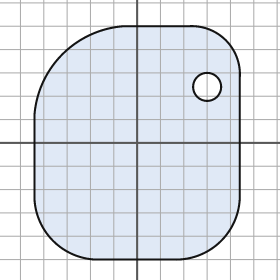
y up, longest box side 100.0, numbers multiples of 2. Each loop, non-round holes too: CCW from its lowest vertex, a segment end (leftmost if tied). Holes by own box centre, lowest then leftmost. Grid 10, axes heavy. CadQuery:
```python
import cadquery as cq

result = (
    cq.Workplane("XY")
    .moveTo(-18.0, -50.0)
    .lineTo(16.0, -50.0)
    .threePointArc((36.0, -42.0), (44.0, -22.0))
    .lineTo(44.0, 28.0)
    .threePointArc((38.0, 44.0), (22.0, 50.0))
    .lineTo(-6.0, 50.0)
    .threePointArc((-32.0, 38.0), (-44.0, 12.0))
    .lineTo(-44.0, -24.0)
    .threePointArc((-36.0, -42.0), (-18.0, -50.0))
    .close()
    .moveTo(30.0, 24.0)
    .circle(6.0)
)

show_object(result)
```